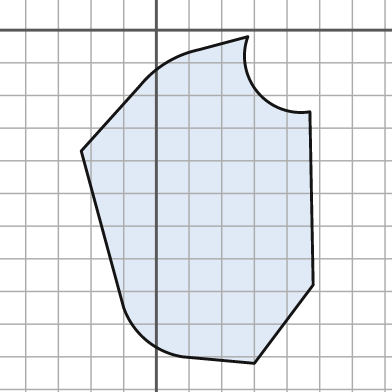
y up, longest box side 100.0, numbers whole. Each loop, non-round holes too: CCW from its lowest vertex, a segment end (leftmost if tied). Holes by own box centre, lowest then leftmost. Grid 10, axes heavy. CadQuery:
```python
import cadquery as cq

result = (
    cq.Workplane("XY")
    .moveTo(30.0, -102.0)
    .lineTo(48.0, -78.0)
    .lineTo(47.0, -25.0)
    .threePointArc((31.0, -19.0), (28.0, -2.0))
    .lineTo(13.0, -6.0)
    .threePointArc((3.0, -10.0), (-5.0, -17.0))
    .lineTo(-23.0, -37.0)
    .lineTo(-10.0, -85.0)
    .threePointArc((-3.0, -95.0), (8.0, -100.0))
    .close()
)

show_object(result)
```